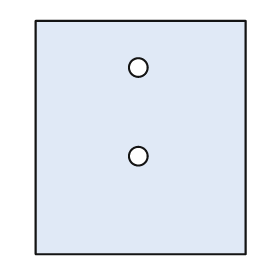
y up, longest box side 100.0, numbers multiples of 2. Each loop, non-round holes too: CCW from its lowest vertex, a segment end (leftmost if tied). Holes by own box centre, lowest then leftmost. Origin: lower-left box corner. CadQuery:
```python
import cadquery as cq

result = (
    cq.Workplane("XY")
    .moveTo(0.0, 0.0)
    .lineTo(90.0, 0.0)
    .lineTo(90.0, 100.0)
    .lineTo(0.0, 100.0)
    .close()
    .moveTo(44.0, 42.0)
    .circle(4.0)
    .moveTo(44.0, 80.0)
    .circle(4.0)
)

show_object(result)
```